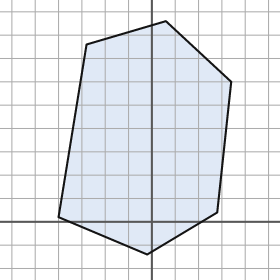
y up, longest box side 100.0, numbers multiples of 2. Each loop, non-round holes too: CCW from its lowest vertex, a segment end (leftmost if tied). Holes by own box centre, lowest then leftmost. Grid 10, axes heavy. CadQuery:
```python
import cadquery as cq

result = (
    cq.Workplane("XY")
    .moveTo(-2.0, -14.0)
    .lineTo(28.0, 4.0)
    .lineTo(34.0, 60.0)
    .lineTo(6.0, 86.0)
    .lineTo(-28.0, 76.0)
    .lineTo(-40.0, 2.0)
    .close()
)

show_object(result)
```